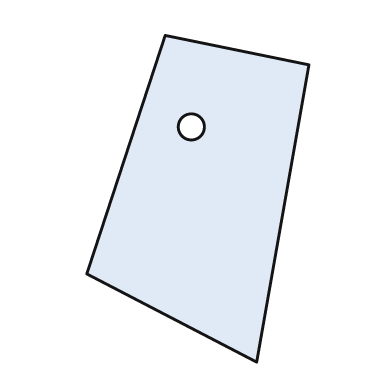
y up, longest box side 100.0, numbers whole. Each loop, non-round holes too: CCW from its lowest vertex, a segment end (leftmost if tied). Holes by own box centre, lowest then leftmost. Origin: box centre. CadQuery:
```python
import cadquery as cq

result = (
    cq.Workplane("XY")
    .moveTo(18.0, -50.0)
    .lineTo(34.0, 41.0)
    .lineTo(-10.0, 50.0)
    .lineTo(-34.0, -23.0)
    .close()
    .moveTo(-2.0, 22.0)
    .circle(4.0)
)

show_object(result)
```